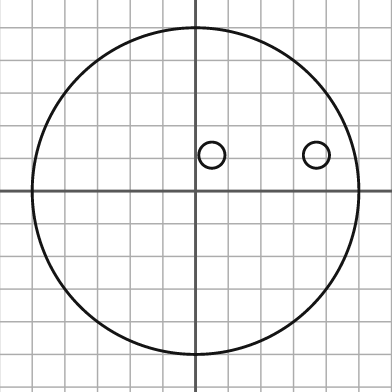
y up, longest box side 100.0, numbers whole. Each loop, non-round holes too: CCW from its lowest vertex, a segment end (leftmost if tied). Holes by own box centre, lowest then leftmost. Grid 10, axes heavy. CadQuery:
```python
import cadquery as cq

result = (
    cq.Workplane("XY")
    .moveTo(0.0, 0.0)
    .circle(50.0)
    .moveTo(5.0, 11.0)
    .circle(4.0)
    .moveTo(37.0, 11.0)
    .circle(4.0)
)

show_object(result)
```